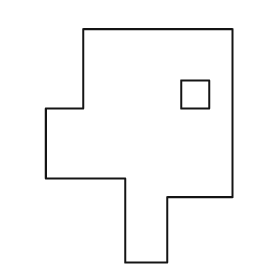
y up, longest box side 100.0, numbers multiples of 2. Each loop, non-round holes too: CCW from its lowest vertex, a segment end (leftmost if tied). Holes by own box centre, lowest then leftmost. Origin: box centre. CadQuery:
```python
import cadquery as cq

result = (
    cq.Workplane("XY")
    .moveTo(-6.0, -50.0)
    .lineTo(12.0, -50.0)
    .lineTo(12.0, -22.0)
    .lineTo(40.0, -22.0)
    .lineTo(40.0, 50.0)
    .lineTo(-24.0, 50.0)
    .lineTo(-24.0, 16.0)
    .lineTo(-40.0, 16.0)
    .lineTo(-40.0, -14.0)
    .lineTo(-6.0, -14.0)
    .close()
    .moveTo(18.0, 16.0)
    .lineTo(30.0, 16.0)
    .lineTo(30.0, 28.0)
    .lineTo(18.0, 28.0)
    .close()
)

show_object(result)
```